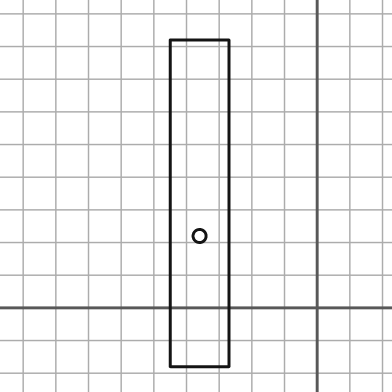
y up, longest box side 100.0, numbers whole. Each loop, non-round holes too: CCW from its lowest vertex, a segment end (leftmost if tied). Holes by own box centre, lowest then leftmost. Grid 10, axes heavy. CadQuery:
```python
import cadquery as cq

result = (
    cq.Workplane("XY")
    .moveTo(-45.0, -18.0)
    .lineTo(-27.0, -18.0)
    .lineTo(-27.0, 82.0)
    .lineTo(-45.0, 82.0)
    .close()
    .moveTo(-36.0, 22.0)
    .circle(2.0)
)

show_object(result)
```